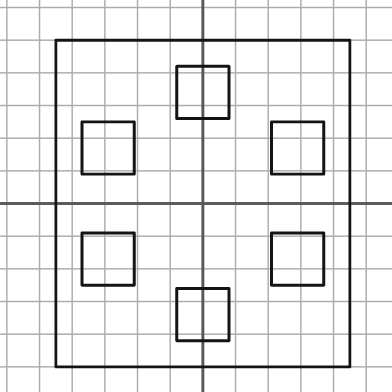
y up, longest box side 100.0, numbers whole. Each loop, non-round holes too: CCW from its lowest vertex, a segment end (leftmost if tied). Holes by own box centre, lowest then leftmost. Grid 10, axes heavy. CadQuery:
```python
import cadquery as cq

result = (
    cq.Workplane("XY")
    .moveTo(-45.0, -50.0)
    .lineTo(45.0, -50.0)
    .lineTo(45.0, 50.0)
    .lineTo(-45.0, 50.0)
    .close()
    .moveTo(-8.0, -42.0)
    .lineTo(8.0, -42.0)
    .lineTo(8.0, -26.0)
    .lineTo(-8.0, -26.0)
    .close()
    .moveTo(-37.0, -25.0)
    .lineTo(-21.0, -25.0)
    .lineTo(-21.0, -9.0)
    .lineTo(-37.0, -9.0)
    .close()
    .moveTo(21.0, -25.0)
    .lineTo(37.0, -25.0)
    .lineTo(37.0, -9.0)
    .lineTo(21.0, -9.0)
    .close()
    .moveTo(-37.0, 9.0)
    .lineTo(-21.0, 9.0)
    .lineTo(-21.0, 25.0)
    .lineTo(-37.0, 25.0)
    .close()
    .moveTo(21.0, 9.0)
    .lineTo(37.0, 9.0)
    .lineTo(37.0, 25.0)
    .lineTo(21.0, 25.0)
    .close()
    .moveTo(-8.0, 26.0)
    .lineTo(8.0, 26.0)
    .lineTo(8.0, 42.0)
    .lineTo(-8.0, 42.0)
    .close()
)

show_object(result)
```